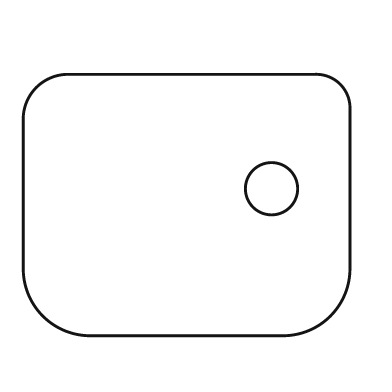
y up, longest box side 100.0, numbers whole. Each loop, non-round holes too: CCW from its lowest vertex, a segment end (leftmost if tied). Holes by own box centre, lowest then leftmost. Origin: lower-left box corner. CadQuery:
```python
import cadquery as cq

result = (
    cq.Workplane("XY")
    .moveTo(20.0, 0.0)
    .lineTo(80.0, 0.0)
    .threePointArc((94.0, 6.0), (100.0, 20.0))
    .lineTo(100.0, 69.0)
    .threePointArc((97.0, 77.0), (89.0, 80.0))
    .lineTo(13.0, 80.0)
    .threePointArc((4.0, 76.0), (0.0, 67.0))
    .lineTo(0.0, 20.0)
    .threePointArc((6.0, 6.0), (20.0, 0.0))
    .close()
    .moveTo(76.0, 45.0)
    .circle(8.0)
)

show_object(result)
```